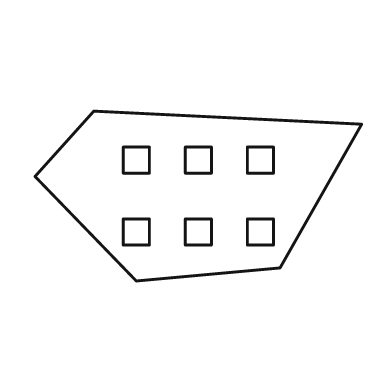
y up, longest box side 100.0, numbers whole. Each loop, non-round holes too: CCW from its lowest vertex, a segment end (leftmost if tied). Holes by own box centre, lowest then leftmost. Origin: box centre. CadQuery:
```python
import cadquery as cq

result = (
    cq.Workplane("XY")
    .moveTo(-19.0, -26.0)
    .lineTo(25.0, -22.0)
    .lineTo(50.0, 22.0)
    .lineTo(-32.0, 26.0)
    .lineTo(-50.0, 6.0)
    .close()
    .moveTo(-23.0, -15.0)
    .lineTo(-15.0, -15.0)
    .lineTo(-15.0, -7.0)
    .lineTo(-23.0, -7.0)
    .close()
    .moveTo(-4.0, -15.0)
    .lineTo(4.0, -15.0)
    .lineTo(4.0, -7.0)
    .lineTo(-4.0, -7.0)
    .close()
    .moveTo(15.0, -15.0)
    .lineTo(23.0, -15.0)
    .lineTo(23.0, -7.0)
    .lineTo(15.0, -7.0)
    .close()
    .moveTo(-23.0, 7.0)
    .lineTo(-15.0, 7.0)
    .lineTo(-15.0, 15.0)
    .lineTo(-23.0, 15.0)
    .close()
    .moveTo(-4.0, 7.0)
    .lineTo(4.0, 7.0)
    .lineTo(4.0, 15.0)
    .lineTo(-4.0, 15.0)
    .close()
    .moveTo(15.0, 7.0)
    .lineTo(23.0, 7.0)
    .lineTo(23.0, 15.0)
    .lineTo(15.0, 15.0)
    .close()
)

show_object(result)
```